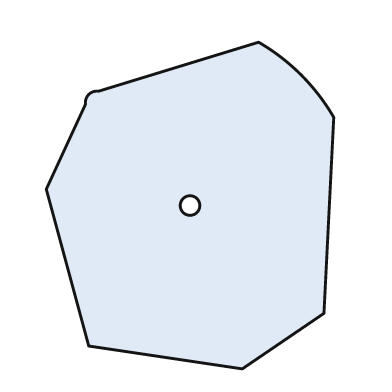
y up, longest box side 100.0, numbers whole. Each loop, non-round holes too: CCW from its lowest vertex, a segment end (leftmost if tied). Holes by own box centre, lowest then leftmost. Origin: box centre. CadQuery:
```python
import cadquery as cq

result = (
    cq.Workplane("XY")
    .moveTo(16.0, -50.0)
    .lineTo(41.0, -33.0)
    .lineTo(44.0, 27.0)
    .threePointArc((34.0, 40.0), (21.0, 50.0))
    .lineTo(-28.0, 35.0)
    .threePointArc((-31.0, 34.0), (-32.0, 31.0))
    .lineTo(-44.0, 5.0)
    .lineTo(-31.0, -43.0)
    .close()
    .moveTo(0.0, 0.0)
    .circle(3.0)
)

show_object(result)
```